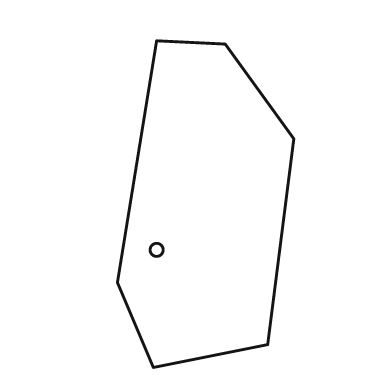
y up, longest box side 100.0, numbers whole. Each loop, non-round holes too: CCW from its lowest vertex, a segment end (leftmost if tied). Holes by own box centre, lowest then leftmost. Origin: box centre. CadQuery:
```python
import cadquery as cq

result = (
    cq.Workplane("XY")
    .moveTo(-16.0, -50.0)
    .lineTo(19.0, -43.0)
    .lineTo(27.0, 20.0)
    .lineTo(6.0, 49.0)
    .lineTo(-15.0, 50.0)
    .lineTo(-27.0, -24.0)
    .close()
    .moveTo(-15.0, -14.0)
    .circle(2.0)
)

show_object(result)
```